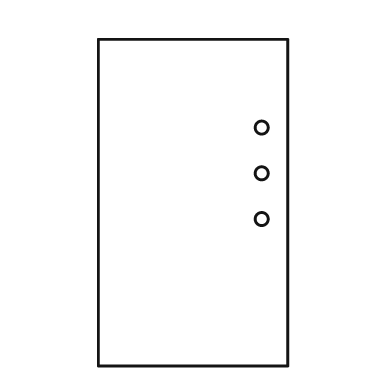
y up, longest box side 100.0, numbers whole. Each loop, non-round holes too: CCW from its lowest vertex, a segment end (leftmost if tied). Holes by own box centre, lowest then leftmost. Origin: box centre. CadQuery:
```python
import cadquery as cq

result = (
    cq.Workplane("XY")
    .moveTo(-29.0, -50.0)
    .lineTo(29.0, -50.0)
    .lineTo(29.0, 50.0)
    .lineTo(-29.0, 50.0)
    .close()
    .moveTo(21.0, -5.0)
    .circle(2.0)
    .moveTo(21.0, 9.0)
    .circle(2.0)
    .moveTo(21.0, 23.0)
    .circle(2.0)
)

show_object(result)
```